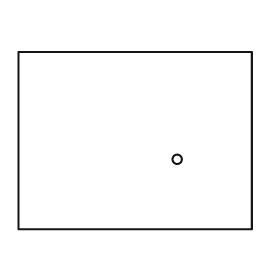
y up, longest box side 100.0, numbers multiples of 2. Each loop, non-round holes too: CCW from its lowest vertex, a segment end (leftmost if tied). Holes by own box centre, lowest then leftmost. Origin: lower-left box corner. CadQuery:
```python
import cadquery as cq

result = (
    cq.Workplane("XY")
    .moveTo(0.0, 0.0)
    .lineTo(100.0, 0.0)
    .lineTo(100.0, 76.0)
    .lineTo(0.0, 76.0)
    .close()
    .moveTo(68.0, 30.0)
    .circle(2.0)
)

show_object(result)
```